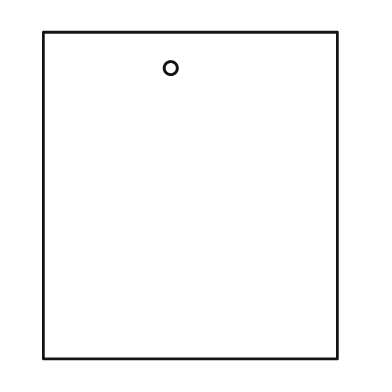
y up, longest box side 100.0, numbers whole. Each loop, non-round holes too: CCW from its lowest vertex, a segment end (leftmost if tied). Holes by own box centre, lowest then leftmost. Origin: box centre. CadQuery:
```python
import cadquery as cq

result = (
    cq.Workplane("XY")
    .moveTo(-45.0, -50.0)
    .lineTo(45.0, -50.0)
    .lineTo(45.0, 50.0)
    .lineTo(-45.0, 50.0)
    .close()
    .moveTo(-6.0, 39.0)
    .circle(2.0)
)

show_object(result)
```